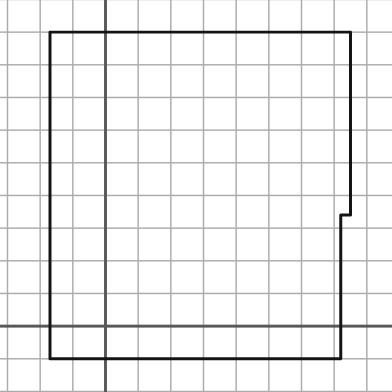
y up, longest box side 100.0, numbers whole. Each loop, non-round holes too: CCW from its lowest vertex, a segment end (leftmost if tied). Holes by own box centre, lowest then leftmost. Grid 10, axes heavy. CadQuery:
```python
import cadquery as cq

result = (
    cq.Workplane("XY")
    .moveTo(-17.0, -10.0)
    .lineTo(72.0, -10.0)
    .lineTo(72.0, 34.0)
    .lineTo(75.0, 34.0)
    .lineTo(75.0, 90.0)
    .lineTo(-17.0, 90.0)
    .close()
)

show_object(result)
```